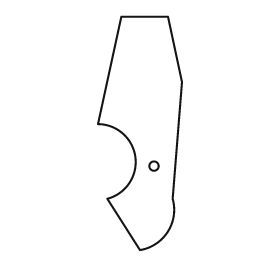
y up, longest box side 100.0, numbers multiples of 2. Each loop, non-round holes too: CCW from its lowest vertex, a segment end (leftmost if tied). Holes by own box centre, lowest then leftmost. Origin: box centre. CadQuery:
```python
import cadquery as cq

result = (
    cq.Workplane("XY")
    .moveTo(0.0, -50.0)
    .threePointArc((12.0, -42.0), (14.0, -28.0))
    .lineTo(18.0, 22.0)
    .lineTo(12.0, 50.0)
    .lineTo(-8.0, 50.0)
    .lineTo(-18.0, 4.0)
    .threePointArc((-2.0, -10.0), (-14.0, -28.0))
    .close()
    .moveTo(6.0, -14.0)
    .circle(2.0)
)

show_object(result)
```